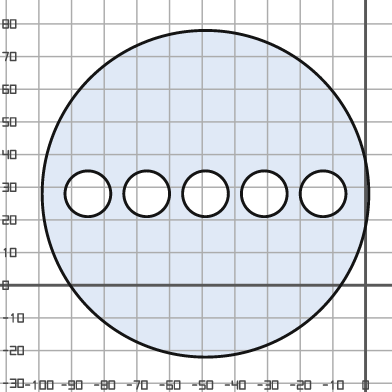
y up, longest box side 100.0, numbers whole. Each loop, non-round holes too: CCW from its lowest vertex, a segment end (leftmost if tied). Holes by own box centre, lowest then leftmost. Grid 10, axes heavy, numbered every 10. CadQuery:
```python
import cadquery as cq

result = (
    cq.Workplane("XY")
    .moveTo(-49.0, 28.0)
    .circle(50.0)
    .moveTo(-85.0, 28.0)
    .circle(7.0)
    .moveTo(-67.0, 28.0)
    .circle(7.0)
    .moveTo(-49.0, 28.0)
    .circle(7.0)
    .moveTo(-31.0, 28.0)
    .circle(7.0)
    .moveTo(-13.0, 28.0)
    .circle(7.0)
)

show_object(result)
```